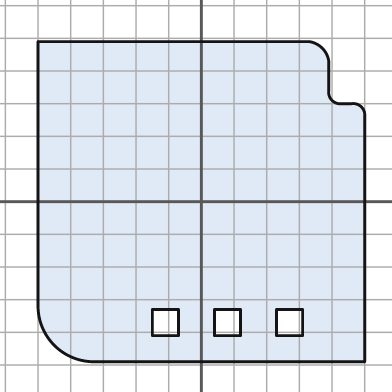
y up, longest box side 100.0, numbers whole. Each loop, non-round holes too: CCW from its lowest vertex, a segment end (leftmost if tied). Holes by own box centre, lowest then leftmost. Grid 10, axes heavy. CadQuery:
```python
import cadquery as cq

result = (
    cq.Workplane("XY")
    .moveTo(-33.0, -49.0)
    .lineTo(50.0, -49.0)
    .lineTo(50.0, 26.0)
    .threePointArc((49.0, 29.0), (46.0, 30.0))
    .lineTo(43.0, 30.0)
    .threePointArc((40.0, 31.0), (39.0, 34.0))
    .lineTo(39.0, 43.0)
    .threePointArc((37.0, 47.0), (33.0, 49.0))
    .lineTo(-50.0, 49.0)
    .lineTo(-50.0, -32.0)
    .threePointArc((-45.0, -44.0), (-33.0, -49.0))
    .close()
    .moveTo(-15.0, -41.0)
    .lineTo(-7.0, -41.0)
    .lineTo(-7.0, -33.0)
    .lineTo(-15.0, -33.0)
    .close()
    .moveTo(4.0, -41.0)
    .lineTo(12.0, -41.0)
    .lineTo(12.0, -33.0)
    .lineTo(4.0, -33.0)
    .close()
    .moveTo(23.0, -41.0)
    .lineTo(31.0, -41.0)
    .lineTo(31.0, -33.0)
    .lineTo(23.0, -33.0)
    .close()
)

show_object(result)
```